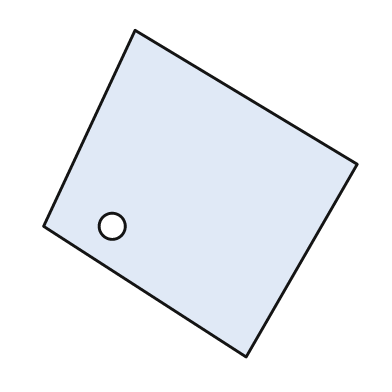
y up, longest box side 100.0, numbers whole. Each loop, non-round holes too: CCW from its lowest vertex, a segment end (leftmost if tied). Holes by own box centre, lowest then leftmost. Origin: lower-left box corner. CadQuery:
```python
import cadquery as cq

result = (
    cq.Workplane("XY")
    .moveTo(62.0, 0.0)
    .lineTo(96.0, 59.0)
    .lineTo(28.0, 100.0)
    .lineTo(0.0, 40.0)
    .close()
    .moveTo(21.0, 40.0)
    .circle(4.0)
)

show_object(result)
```